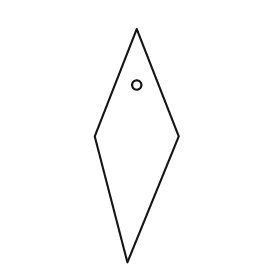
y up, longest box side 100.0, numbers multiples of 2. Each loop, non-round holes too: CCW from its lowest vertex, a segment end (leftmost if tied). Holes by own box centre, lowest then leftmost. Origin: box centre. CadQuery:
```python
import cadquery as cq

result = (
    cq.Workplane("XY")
    .moveTo(-4.0, -50.0)
    .lineTo(18.0, 4.0)
    .lineTo(0.0, 50.0)
    .lineTo(-18.0, 4.0)
    .close()
    .moveTo(0.0, 26.0)
    .circle(2.0)
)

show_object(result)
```